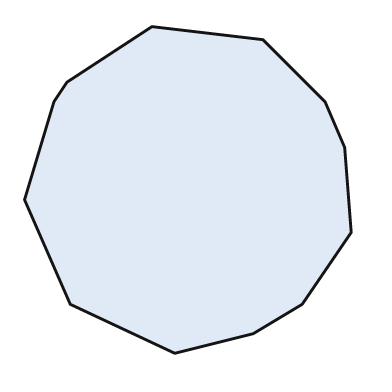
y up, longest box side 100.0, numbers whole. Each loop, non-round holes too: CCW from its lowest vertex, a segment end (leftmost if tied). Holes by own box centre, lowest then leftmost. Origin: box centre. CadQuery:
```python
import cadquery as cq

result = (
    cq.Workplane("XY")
    .moveTo(-4.0, -50.0)
    .lineTo(20.0, -44.0)
    .lineTo(35.0, -35.0)
    .lineTo(50.0, -13.0)
    .lineTo(48.0, 13.0)
    .lineTo(42.0, 27.0)
    .lineTo(23.0, 46.0)
    .lineTo(-11.0, 50.0)
    .lineTo(-37.0, 33.0)
    .lineTo(-41.0, 27.0)
    .lineTo(-50.0, -3.0)
    .lineTo(-36.0, -35.0)
    .close()
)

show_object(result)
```